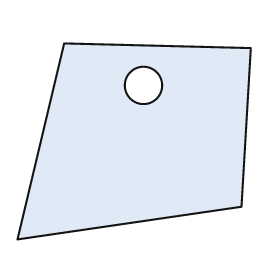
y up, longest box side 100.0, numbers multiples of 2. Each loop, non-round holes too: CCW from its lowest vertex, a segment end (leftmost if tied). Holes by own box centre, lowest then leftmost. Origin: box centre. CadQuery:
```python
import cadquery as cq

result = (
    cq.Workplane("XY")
    .moveTo(-50.0, -42.0)
    .lineTo(46.0, -28.0)
    .lineTo(50.0, 40.0)
    .lineTo(-30.0, 42.0)
    .close()
    .moveTo(4.0, 24.0)
    .circle(8.0)
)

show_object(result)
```